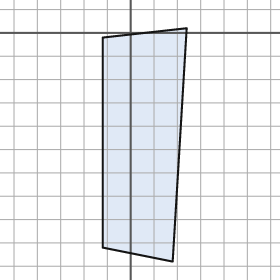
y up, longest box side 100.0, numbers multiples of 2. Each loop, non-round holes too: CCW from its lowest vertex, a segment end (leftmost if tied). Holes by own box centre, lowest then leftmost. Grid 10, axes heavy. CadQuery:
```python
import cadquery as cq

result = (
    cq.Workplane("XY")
    .moveTo(18.0, -98.0)
    .lineTo(24.0, 2.0)
    .lineTo(-12.0, -2.0)
    .lineTo(-12.0, -92.0)
    .close()
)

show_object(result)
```